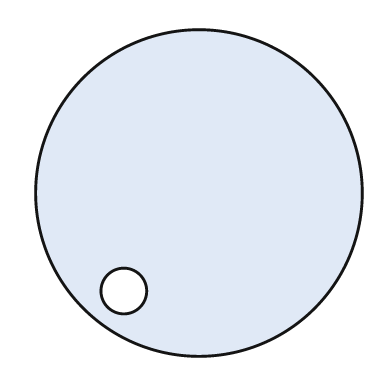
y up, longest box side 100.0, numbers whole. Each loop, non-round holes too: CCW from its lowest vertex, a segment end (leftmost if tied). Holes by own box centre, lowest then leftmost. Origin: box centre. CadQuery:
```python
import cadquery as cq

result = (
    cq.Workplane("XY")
    .moveTo(0.0, 0.0)
    .circle(50.0)
    .moveTo(-23.0, -30.0)
    .circle(7.0)
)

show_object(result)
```